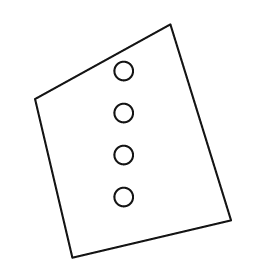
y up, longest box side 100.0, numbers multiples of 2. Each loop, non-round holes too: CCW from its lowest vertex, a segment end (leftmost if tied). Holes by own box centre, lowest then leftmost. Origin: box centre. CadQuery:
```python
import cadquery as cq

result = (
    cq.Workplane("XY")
    .moveTo(-26.0, -50.0)
    .lineTo(42.0, -34.0)
    .lineTo(16.0, 50.0)
    .lineTo(-42.0, 18.0)
    .close()
    .moveTo(-4.0, -24.0)
    .circle(4.0)
    .moveTo(-4.0, -6.0)
    .circle(4.0)
    .moveTo(-4.0, 12.0)
    .circle(4.0)
    .moveTo(-4.0, 30.0)
    .circle(4.0)
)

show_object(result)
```